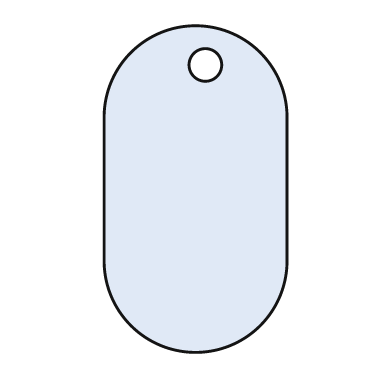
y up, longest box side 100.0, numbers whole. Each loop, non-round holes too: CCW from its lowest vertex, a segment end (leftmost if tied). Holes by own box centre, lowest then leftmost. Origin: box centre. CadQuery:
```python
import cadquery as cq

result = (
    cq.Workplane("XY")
    .moveTo(-28.0, -22.0)
    .threePointArc((0.0, -50.0), (28.0, -22.0))
    .lineTo(28.0, 22.0)
    .threePointArc((0.0, 50.0), (-28.0, 22.0))
    .close()
    .moveTo(3.0, 38.0)
    .circle(5.0)
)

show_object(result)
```